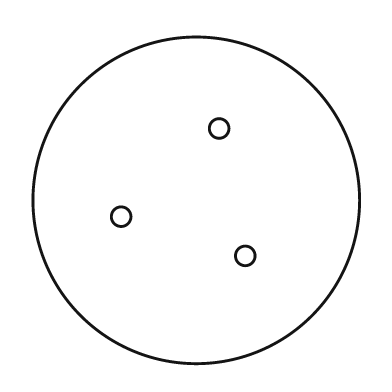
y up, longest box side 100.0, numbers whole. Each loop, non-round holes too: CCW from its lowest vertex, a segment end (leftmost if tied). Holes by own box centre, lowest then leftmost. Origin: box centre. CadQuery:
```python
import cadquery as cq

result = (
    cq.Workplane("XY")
    .moveTo(0.0, 0.0)
    .circle(50.0)
    .moveTo(15.0, -17.0)
    .circle(3.0)
    .moveTo(-23.0, -5.0)
    .circle(3.0)
    .moveTo(7.0, 22.0)
    .circle(3.0)
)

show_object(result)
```